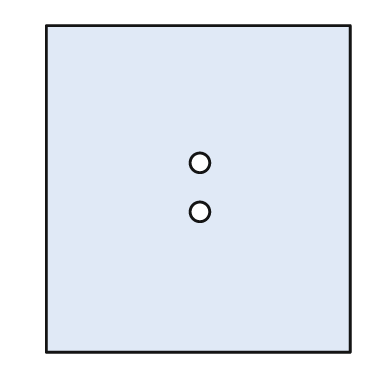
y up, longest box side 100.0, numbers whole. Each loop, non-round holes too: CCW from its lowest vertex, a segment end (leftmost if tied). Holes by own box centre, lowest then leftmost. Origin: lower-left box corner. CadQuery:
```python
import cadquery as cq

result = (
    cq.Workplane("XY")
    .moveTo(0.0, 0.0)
    .lineTo(93.0, 0.0)
    .lineTo(93.0, 100.0)
    .lineTo(0.0, 100.0)
    .close()
    .moveTo(47.0, 43.0)
    .circle(3.0)
    .moveTo(47.0, 58.0)
    .circle(3.0)
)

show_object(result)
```